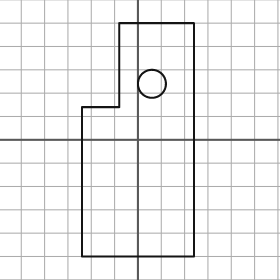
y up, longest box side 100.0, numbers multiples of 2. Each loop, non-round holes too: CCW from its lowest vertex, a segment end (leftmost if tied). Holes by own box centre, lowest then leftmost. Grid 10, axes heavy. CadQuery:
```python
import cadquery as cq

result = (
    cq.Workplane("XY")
    .moveTo(-24.0, -50.0)
    .lineTo(24.0, -50.0)
    .lineTo(24.0, 50.0)
    .lineTo(-8.0, 50.0)
    .lineTo(-8.0, 14.0)
    .lineTo(-24.0, 14.0)
    .close()
    .moveTo(6.0, 24.0)
    .circle(6.0)
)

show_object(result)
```